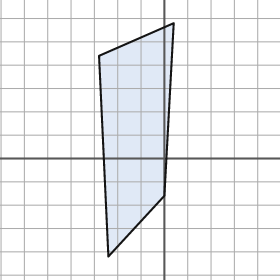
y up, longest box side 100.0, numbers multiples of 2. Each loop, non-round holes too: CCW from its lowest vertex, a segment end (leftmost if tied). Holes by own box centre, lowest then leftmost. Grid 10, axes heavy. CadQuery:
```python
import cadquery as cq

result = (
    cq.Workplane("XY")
    .moveTo(-24.0, -42.0)
    .lineTo(0.0, -16.0)
    .lineTo(4.0, 58.0)
    .lineTo(-28.0, 44.0)
    .close()
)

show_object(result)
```